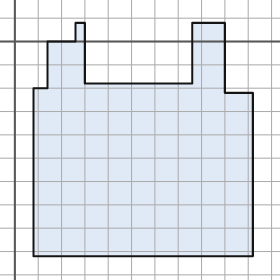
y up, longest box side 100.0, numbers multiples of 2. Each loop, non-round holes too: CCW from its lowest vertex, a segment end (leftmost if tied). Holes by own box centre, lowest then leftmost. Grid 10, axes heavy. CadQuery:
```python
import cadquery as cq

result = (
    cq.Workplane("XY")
    .moveTo(8.0, -92.0)
    .lineTo(102.0, -92.0)
    .lineTo(102.0, -22.0)
    .lineTo(90.0, -22.0)
    .lineTo(90.0, 8.0)
    .lineTo(76.0, 8.0)
    .lineTo(76.0, -18.0)
    .lineTo(30.0, -18.0)
    .lineTo(30.0, 8.0)
    .lineTo(26.0, 8.0)
    .lineTo(26.0, 0.0)
    .lineTo(14.0, 0.0)
    .lineTo(14.0, -20.0)
    .lineTo(8.0, -20.0)
    .close()
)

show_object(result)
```